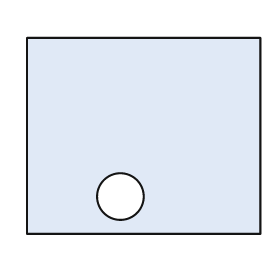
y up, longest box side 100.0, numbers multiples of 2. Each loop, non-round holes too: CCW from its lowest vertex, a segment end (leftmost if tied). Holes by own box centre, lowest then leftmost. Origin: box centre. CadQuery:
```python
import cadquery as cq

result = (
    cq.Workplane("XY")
    .moveTo(-50.0, -42.0)
    .lineTo(50.0, -42.0)
    .lineTo(50.0, 42.0)
    .lineTo(-50.0, 42.0)
    .close()
    .moveTo(-10.0, -26.0)
    .circle(10.0)
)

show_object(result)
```